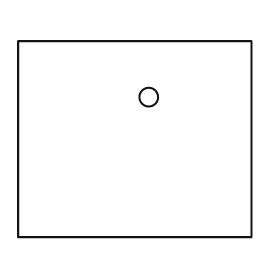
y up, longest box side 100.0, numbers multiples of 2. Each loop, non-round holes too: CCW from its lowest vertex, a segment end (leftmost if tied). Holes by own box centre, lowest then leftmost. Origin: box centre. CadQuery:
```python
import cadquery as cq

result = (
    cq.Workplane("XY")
    .moveTo(-50.0, -42.0)
    .lineTo(50.0, -42.0)
    .lineTo(50.0, 42.0)
    .lineTo(-50.0, 42.0)
    .close()
    .moveTo(6.0, 18.0)
    .circle(4.0)
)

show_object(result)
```